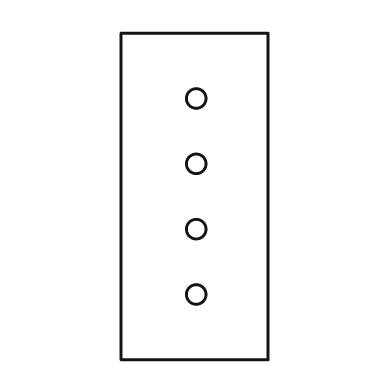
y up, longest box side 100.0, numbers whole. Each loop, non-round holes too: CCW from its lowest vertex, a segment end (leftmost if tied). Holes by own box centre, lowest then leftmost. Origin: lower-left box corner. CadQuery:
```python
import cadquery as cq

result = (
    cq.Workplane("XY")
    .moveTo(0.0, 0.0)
    .lineTo(45.0, 0.0)
    .lineTo(45.0, 100.0)
    .lineTo(0.0, 100.0)
    .close()
    .moveTo(23.0, 20.0)
    .circle(3.0)
    .moveTo(23.0, 40.0)
    .circle(3.0)
    .moveTo(23.0, 60.0)
    .circle(3.0)
    .moveTo(23.0, 80.0)
    .circle(3.0)
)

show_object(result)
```